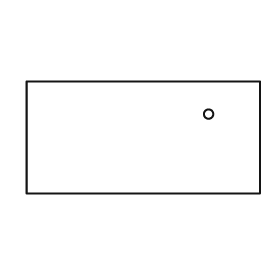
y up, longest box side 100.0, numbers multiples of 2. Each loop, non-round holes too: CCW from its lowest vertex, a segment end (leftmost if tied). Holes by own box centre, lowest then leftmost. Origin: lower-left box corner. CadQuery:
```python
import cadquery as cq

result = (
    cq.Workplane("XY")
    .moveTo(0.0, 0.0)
    .lineTo(100.0, 0.0)
    .lineTo(100.0, 48.0)
    .lineTo(0.0, 48.0)
    .close()
    .moveTo(78.0, 34.0)
    .circle(2.0)
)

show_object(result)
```